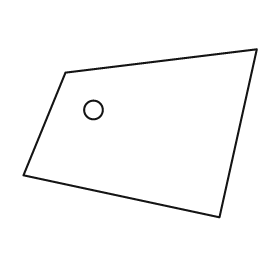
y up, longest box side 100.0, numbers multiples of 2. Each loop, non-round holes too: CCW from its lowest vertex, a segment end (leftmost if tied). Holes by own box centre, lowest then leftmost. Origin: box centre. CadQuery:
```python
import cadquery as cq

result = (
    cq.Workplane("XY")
    .moveTo(34.0, -36.0)
    .lineTo(50.0, 36.0)
    .lineTo(-32.0, 26.0)
    .lineTo(-50.0, -18.0)
    .close()
    .moveTo(-20.0, 10.0)
    .circle(4.0)
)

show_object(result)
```